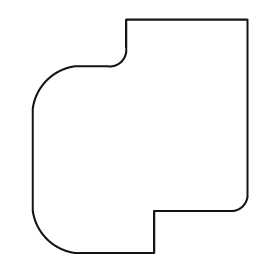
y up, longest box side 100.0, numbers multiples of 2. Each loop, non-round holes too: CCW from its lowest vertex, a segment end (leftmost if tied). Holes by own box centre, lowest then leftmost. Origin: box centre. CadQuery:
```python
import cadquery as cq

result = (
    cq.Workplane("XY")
    .moveTo(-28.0, -50.0)
    .lineTo(6.0, -50.0)
    .lineTo(6.0, -32.0)
    .lineTo(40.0, -32.0)
    .threePointArc((44.0, -30.0), (46.0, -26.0))
    .lineTo(46.0, 50.0)
    .lineTo(-6.0, 50.0)
    .lineTo(-6.0, 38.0)
    .threePointArc((-8.0, 32.0), (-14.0, 30.0))
    .lineTo(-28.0, 30.0)
    .threePointArc((-40.0, 24.0), (-46.0, 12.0))
    .lineTo(-46.0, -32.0)
    .threePointArc((-40.0, -44.0), (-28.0, -50.0))
    .close()
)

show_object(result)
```